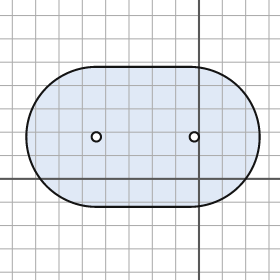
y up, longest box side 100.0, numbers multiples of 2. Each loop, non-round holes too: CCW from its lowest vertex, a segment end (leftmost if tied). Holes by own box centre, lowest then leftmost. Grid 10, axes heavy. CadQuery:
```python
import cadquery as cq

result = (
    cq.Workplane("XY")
    .moveTo(-44.0, -12.0)
    .lineTo(-4.0, -12.0)
    .threePointArc((26.0, 18.0), (-4.0, 48.0))
    .lineTo(-44.0, 48.0)
    .threePointArc((-74.0, 18.0), (-44.0, -12.0))
    .close()
    .moveTo(-44.0, 18.0)
    .circle(2.0)
    .moveTo(-2.0, 18.0)
    .circle(2.0)
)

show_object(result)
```